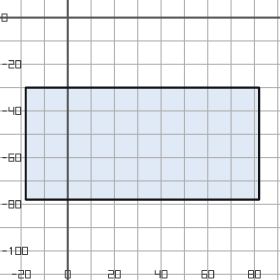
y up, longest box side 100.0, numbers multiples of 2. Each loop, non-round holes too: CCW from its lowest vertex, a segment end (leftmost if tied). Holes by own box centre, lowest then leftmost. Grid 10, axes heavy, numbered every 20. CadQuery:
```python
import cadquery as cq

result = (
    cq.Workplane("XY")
    .moveTo(-18.0, -78.0)
    .lineTo(82.0, -78.0)
    .lineTo(82.0, -30.0)
    .lineTo(-18.0, -30.0)
    .close()
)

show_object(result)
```